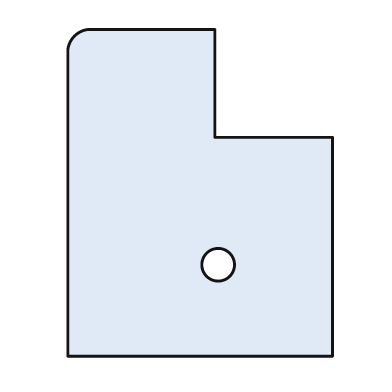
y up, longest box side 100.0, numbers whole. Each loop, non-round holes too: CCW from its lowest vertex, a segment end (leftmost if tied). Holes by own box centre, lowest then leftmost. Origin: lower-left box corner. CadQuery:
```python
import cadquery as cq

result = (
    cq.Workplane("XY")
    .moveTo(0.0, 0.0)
    .lineTo(81.0, 0.0)
    .lineTo(81.0, 67.0)
    .lineTo(45.0, 67.0)
    .lineTo(45.0, 100.0)
    .lineTo(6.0, 100.0)
    .threePointArc((2.0, 98.0), (0.0, 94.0))
    .close()
    .moveTo(46.0, 28.0)
    .circle(5.0)
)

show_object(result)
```